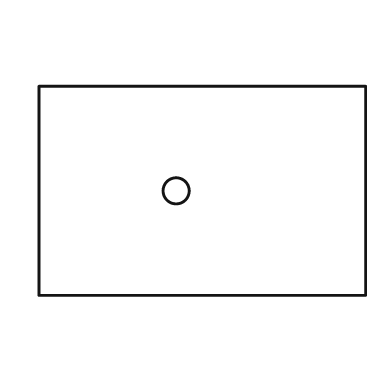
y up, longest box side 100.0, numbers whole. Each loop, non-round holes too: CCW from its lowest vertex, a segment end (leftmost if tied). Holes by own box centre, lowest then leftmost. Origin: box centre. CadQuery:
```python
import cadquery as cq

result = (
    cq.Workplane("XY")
    .moveTo(-50.0, -32.0)
    .lineTo(50.0, -32.0)
    .lineTo(50.0, 32.0)
    .lineTo(-50.0, 32.0)
    .close()
    .moveTo(-8.0, 0.0)
    .circle(4.0)
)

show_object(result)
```